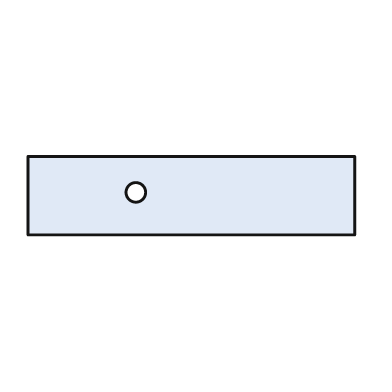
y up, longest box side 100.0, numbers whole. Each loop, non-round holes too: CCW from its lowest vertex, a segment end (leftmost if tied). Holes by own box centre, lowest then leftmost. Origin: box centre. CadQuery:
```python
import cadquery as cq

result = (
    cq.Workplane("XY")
    .moveTo(-50.0, -12.0)
    .lineTo(50.0, -12.0)
    .lineTo(50.0, 12.0)
    .lineTo(-50.0, 12.0)
    .close()
    .moveTo(-17.0, 1.0)
    .circle(3.0)
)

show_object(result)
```